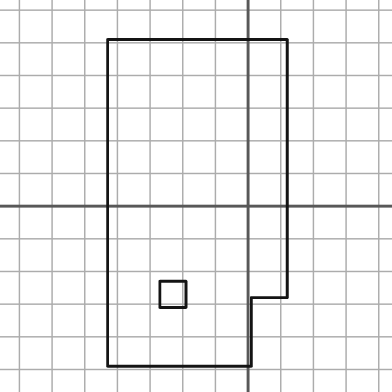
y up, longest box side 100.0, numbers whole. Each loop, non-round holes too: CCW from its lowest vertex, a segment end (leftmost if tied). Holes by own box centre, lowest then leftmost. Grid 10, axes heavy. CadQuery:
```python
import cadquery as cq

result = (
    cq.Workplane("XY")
    .moveTo(-43.0, -49.0)
    .lineTo(1.0, -49.0)
    .lineTo(1.0, -28.0)
    .lineTo(12.0, -28.0)
    .lineTo(12.0, 51.0)
    .lineTo(-43.0, 51.0)
    .close()
    .moveTo(-27.0, -31.0)
    .lineTo(-19.0, -31.0)
    .lineTo(-19.0, -23.0)
    .lineTo(-27.0, -23.0)
    .close()
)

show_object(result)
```